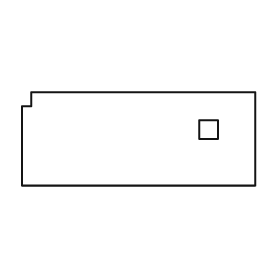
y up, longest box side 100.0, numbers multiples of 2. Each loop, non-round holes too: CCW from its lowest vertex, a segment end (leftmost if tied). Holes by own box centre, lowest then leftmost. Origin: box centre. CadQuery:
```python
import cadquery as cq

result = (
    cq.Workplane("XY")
    .moveTo(-50.0, -20.0)
    .lineTo(50.0, -20.0)
    .lineTo(50.0, 20.0)
    .lineTo(-46.0, 20.0)
    .lineTo(-46.0, 14.0)
    .lineTo(-50.0, 14.0)
    .close()
    .moveTo(26.0, 0.0)
    .lineTo(34.0, 0.0)
    .lineTo(34.0, 8.0)
    .lineTo(26.0, 8.0)
    .close()
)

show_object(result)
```